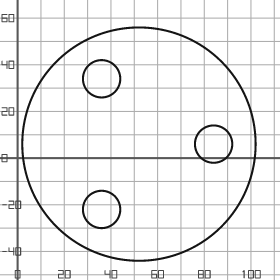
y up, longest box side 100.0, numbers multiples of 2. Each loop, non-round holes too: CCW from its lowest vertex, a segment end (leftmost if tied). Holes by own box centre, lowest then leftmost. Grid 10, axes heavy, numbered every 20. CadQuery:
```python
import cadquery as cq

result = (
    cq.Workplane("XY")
    .moveTo(52.0, 6.0)
    .circle(50.0)
    .moveTo(36.0, -22.0)
    .circle(8.0)
    .moveTo(84.0, 6.0)
    .circle(8.0)
    .moveTo(36.0, 34.0)
    .circle(8.0)
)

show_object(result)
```